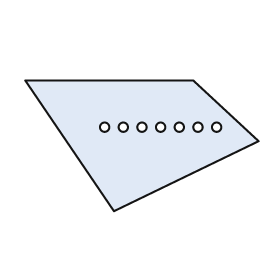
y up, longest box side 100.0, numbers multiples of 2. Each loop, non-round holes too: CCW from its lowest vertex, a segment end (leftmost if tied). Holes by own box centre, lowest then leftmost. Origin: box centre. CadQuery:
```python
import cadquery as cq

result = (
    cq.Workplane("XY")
    .moveTo(-12.0, -28.0)
    .lineTo(50.0, 2.0)
    .lineTo(22.0, 28.0)
    .lineTo(-50.0, 28.0)
    .close()
    .moveTo(-16.0, 8.0)
    .circle(2.0)
    .moveTo(-8.0, 8.0)
    .circle(2.0)
    .moveTo(0.0, 8.0)
    .circle(2.0)
    .moveTo(8.0, 8.0)
    .circle(2.0)
    .moveTo(16.0, 8.0)
    .circle(2.0)
    .moveTo(24.0, 8.0)
    .circle(2.0)
    .moveTo(32.0, 8.0)
    .circle(2.0)
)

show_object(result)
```